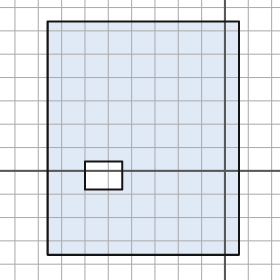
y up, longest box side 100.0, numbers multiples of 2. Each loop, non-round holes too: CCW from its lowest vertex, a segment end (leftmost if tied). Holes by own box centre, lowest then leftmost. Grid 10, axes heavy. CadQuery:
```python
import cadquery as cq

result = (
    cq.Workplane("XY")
    .moveTo(-76.0, -36.0)
    .lineTo(6.0, -36.0)
    .lineTo(6.0, 64.0)
    .lineTo(-76.0, 64.0)
    .close()
    .moveTo(-60.0, -8.0)
    .lineTo(-44.0, -8.0)
    .lineTo(-44.0, 4.0)
    .lineTo(-60.0, 4.0)
    .close()
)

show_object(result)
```